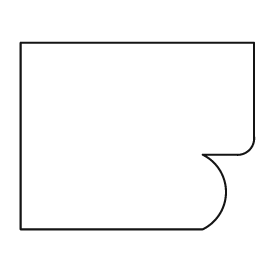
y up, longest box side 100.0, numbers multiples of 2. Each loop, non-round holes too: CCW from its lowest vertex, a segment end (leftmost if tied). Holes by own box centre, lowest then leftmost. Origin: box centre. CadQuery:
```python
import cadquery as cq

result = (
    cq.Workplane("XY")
    .moveTo(-50.0, -40.0)
    .lineTo(28.0, -40.0)
    .threePointArc((38.0, -24.0), (28.0, -8.0))
    .lineTo(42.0, -8.0)
    .threePointArc((48.0, -6.0), (50.0, 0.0))
    .lineTo(50.0, 40.0)
    .lineTo(-50.0, 40.0)
    .close()
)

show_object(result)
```